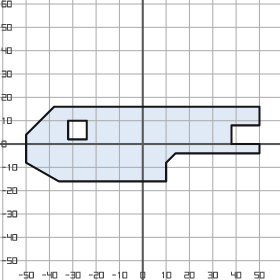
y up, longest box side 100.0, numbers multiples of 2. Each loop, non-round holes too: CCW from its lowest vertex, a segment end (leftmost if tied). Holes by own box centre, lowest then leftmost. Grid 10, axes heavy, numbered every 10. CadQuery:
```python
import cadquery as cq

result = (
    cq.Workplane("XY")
    .moveTo(-36.0, -16.0)
    .lineTo(10.0, -16.0)
    .lineTo(10.0, -8.0)
    .lineTo(14.0, -4.0)
    .lineTo(50.0, -4.0)
    .lineTo(50.0, 0.0)
    .lineTo(38.0, 0.0)
    .lineTo(38.0, 8.0)
    .lineTo(50.0, 8.0)
    .lineTo(50.0, 16.0)
    .lineTo(-38.0, 16.0)
    .lineTo(-50.0, 4.0)
    .lineTo(-50.0, -8.0)
    .close()
    .moveTo(-32.0, 2.0)
    .lineTo(-24.0, 2.0)
    .lineTo(-24.0, 10.0)
    .lineTo(-32.0, 10.0)
    .close()
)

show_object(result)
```